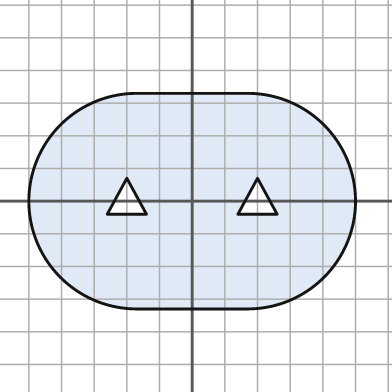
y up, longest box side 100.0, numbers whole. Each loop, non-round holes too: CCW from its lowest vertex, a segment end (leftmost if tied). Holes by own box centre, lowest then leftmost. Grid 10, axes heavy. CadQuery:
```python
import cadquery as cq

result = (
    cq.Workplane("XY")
    .moveTo(-17.0, -33.0)
    .lineTo(17.0, -33.0)
    .threePointArc((50.0, 0.0), (17.0, 33.0))
    .lineTo(-17.0, 33.0)
    .threePointArc((-50.0, 0.0), (-17.0, -33.0))
    .close()
    .moveTo(-26.0, -4.0)
    .lineTo(-14.0, -4.0)
    .lineTo(-20.0, 7.0)
    .close()
    .moveTo(14.0, -4.0)
    .lineTo(26.0, -4.0)
    .lineTo(20.0, 7.0)
    .close()
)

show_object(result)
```